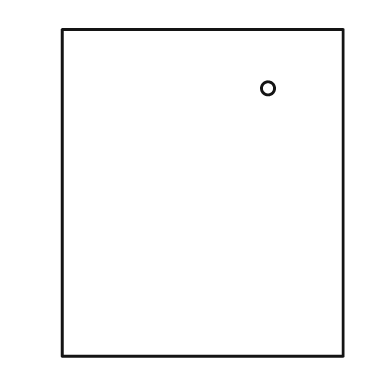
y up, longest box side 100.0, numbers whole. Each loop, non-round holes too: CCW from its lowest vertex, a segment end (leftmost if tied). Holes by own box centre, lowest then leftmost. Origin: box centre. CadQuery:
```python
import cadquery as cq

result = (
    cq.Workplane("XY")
    .moveTo(-43.0, -50.0)
    .lineTo(43.0, -50.0)
    .lineTo(43.0, 50.0)
    .lineTo(-43.0, 50.0)
    .close()
    .moveTo(20.0, 32.0)
    .circle(2.0)
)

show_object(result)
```